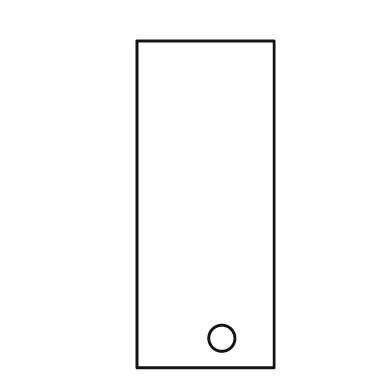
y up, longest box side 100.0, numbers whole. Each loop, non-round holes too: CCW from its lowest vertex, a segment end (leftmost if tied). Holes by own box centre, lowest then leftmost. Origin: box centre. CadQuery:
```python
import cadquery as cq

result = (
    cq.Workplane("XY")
    .moveTo(-21.0, -50.0)
    .lineTo(21.0, -50.0)
    .lineTo(21.0, 50.0)
    .lineTo(-21.0, 50.0)
    .close()
    .moveTo(5.0, -41.0)
    .circle(4.0)
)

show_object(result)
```